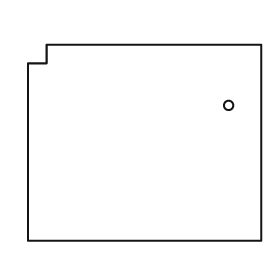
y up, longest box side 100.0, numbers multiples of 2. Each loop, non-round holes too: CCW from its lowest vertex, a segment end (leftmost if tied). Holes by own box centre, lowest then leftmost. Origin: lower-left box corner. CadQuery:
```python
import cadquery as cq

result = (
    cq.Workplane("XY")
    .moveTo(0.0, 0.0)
    .lineTo(100.0, 0.0)
    .lineTo(100.0, 84.0)
    .lineTo(8.0, 84.0)
    .lineTo(8.0, 76.0)
    .lineTo(0.0, 76.0)
    .close()
    .moveTo(86.0, 58.0)
    .circle(2.0)
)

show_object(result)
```